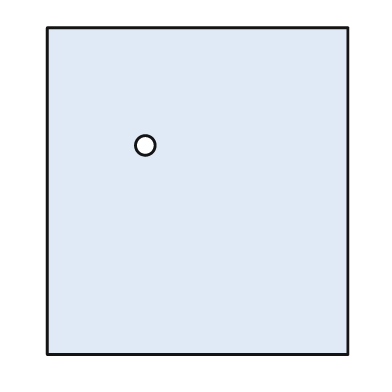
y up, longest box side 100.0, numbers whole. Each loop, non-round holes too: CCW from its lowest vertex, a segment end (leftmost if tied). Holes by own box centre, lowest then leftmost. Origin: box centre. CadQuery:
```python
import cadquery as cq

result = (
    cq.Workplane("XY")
    .moveTo(-46.0, -50.0)
    .lineTo(46.0, -50.0)
    .lineTo(46.0, 50.0)
    .lineTo(-46.0, 50.0)
    .close()
    .moveTo(-16.0, 14.0)
    .circle(3.0)
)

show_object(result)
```